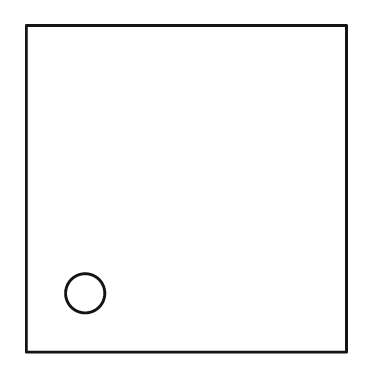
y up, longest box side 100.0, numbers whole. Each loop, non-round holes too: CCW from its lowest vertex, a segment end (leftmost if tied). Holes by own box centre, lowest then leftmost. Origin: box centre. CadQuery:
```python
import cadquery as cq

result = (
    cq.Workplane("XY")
    .moveTo(-49.0, -50.0)
    .lineTo(49.0, -50.0)
    .lineTo(49.0, 50.0)
    .lineTo(-49.0, 50.0)
    .close()
    .moveTo(-31.0, -32.0)
    .circle(6.0)
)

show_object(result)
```